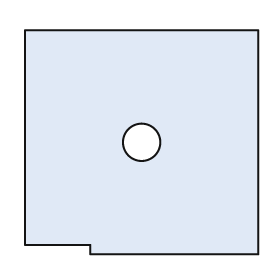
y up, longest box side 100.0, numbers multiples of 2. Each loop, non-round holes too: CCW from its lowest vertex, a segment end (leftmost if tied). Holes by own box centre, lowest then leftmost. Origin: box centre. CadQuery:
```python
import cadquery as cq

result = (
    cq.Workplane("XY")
    .moveTo(-22.0, -48.0)
    .lineTo(50.0, -48.0)
    .lineTo(50.0, 48.0)
    .lineTo(-50.0, 48.0)
    .lineTo(-50.0, -44.0)
    .lineTo(-22.0, -44.0)
    .close()
    .moveTo(0.0, 0.0)
    .circle(8.0)
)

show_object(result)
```